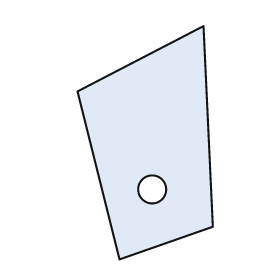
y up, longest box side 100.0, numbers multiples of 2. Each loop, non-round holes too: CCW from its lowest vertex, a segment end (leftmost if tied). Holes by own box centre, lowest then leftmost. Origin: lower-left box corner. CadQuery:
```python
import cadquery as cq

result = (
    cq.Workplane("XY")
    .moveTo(18.0, 0.0)
    .lineTo(58.0, 14.0)
    .lineTo(54.0, 100.0)
    .lineTo(0.0, 72.0)
    .close()
    .moveTo(32.0, 30.0)
    .circle(6.0)
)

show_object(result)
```